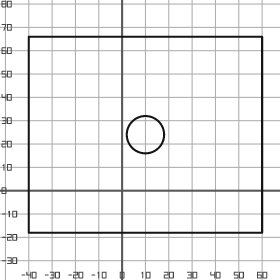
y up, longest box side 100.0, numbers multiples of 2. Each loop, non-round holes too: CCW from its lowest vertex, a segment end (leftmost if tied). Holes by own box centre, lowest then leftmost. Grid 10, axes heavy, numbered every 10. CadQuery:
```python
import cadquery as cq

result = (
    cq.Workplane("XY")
    .moveTo(-40.0, -18.0)
    .lineTo(60.0, -18.0)
    .lineTo(60.0, 66.0)
    .lineTo(-40.0, 66.0)
    .close()
    .moveTo(10.0, 24.0)
    .circle(8.0)
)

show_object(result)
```